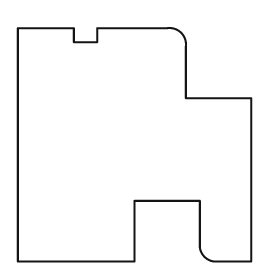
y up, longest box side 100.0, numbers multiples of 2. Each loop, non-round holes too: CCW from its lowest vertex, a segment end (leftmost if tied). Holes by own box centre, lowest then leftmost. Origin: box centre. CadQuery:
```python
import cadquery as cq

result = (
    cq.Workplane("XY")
    .moveTo(-50.0, -50.0)
    .lineTo(0.0, -50.0)
    .lineTo(0.0, -24.0)
    .lineTo(28.0, -24.0)
    .lineTo(28.0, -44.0)
    .threePointArc((30.0, -48.0), (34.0, -50.0))
    .lineTo(50.0, -50.0)
    .lineTo(50.0, 20.0)
    .lineTo(22.0, 20.0)
    .lineTo(22.0, 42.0)
    .threePointArc((20.0, 48.0), (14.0, 50.0))
    .lineTo(-16.0, 50.0)
    .lineTo(-16.0, 44.0)
    .lineTo(-26.0, 44.0)
    .lineTo(-26.0, 50.0)
    .lineTo(-50.0, 50.0)
    .close()
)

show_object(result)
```